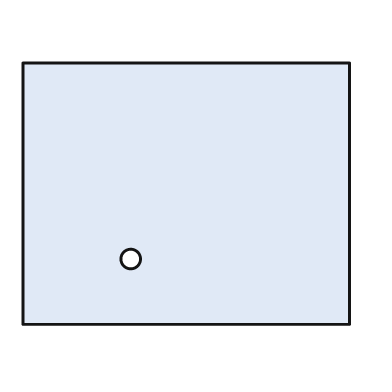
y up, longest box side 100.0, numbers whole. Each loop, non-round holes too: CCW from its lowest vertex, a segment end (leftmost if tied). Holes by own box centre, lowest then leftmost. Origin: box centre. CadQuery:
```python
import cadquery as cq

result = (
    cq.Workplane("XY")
    .moveTo(-50.0, -40.0)
    .lineTo(50.0, -40.0)
    .lineTo(50.0, 40.0)
    .lineTo(-50.0, 40.0)
    .close()
    .moveTo(-17.0, -20.0)
    .circle(3.0)
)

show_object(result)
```